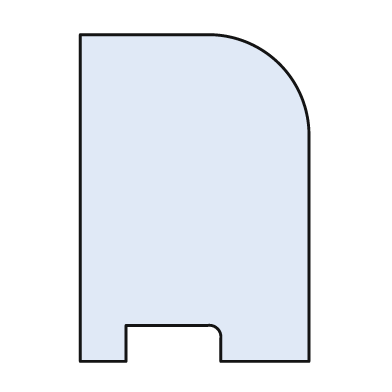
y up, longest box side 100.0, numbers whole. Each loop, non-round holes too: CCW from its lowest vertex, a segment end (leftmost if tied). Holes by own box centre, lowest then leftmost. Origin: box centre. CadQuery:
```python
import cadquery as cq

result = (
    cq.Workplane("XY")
    .moveTo(-35.0, -50.0)
    .lineTo(-21.0, -50.0)
    .lineTo(-21.0, -39.0)
    .lineTo(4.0, -39.0)
    .threePointArc((7.0, -40.0), (8.0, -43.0))
    .lineTo(8.0, -50.0)
    .lineTo(35.0, -50.0)
    .lineTo(35.0, 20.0)
    .threePointArc((26.0, 41.0), (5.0, 50.0))
    .lineTo(-35.0, 50.0)
    .close()
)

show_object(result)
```